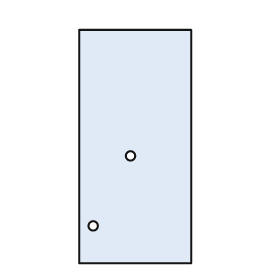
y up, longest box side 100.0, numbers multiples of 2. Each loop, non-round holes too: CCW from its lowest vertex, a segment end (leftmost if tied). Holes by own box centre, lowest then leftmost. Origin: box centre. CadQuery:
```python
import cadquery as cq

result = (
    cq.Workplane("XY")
    .moveTo(-24.0, -50.0)
    .lineTo(24.0, -50.0)
    .lineTo(24.0, 50.0)
    .lineTo(-24.0, 50.0)
    .close()
    .moveTo(-18.0, -34.0)
    .circle(2.0)
    .moveTo(-2.0, -4.0)
    .circle(2.0)
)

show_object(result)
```